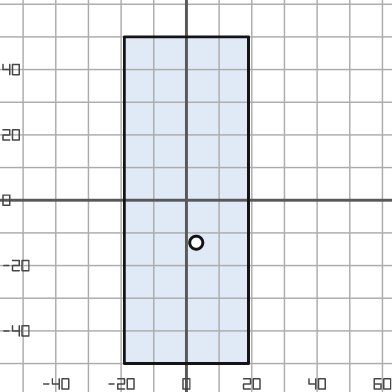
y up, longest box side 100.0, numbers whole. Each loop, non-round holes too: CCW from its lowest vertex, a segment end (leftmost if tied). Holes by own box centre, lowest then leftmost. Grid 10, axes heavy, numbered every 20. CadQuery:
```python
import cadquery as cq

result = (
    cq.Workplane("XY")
    .moveTo(-19.0, -50.0)
    .lineTo(19.0, -50.0)
    .lineTo(19.0, 50.0)
    .lineTo(-19.0, 50.0)
    .close()
    .moveTo(3.0, -13.0)
    .circle(2.0)
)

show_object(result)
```